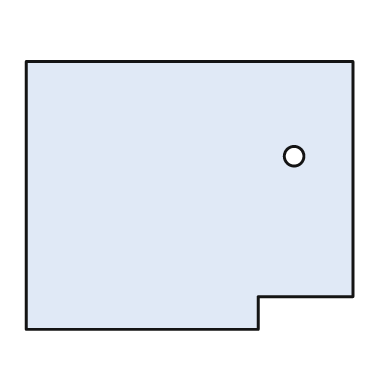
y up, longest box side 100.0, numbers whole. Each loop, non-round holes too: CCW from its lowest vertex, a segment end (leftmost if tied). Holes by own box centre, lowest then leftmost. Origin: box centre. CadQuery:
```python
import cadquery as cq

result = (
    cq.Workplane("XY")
    .moveTo(-50.0, -41.0)
    .lineTo(21.0, -41.0)
    .lineTo(21.0, -31.0)
    .lineTo(50.0, -31.0)
    .lineTo(50.0, 41.0)
    .lineTo(-50.0, 41.0)
    .close()
    .moveTo(32.0, 12.0)
    .circle(3.0)
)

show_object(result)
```